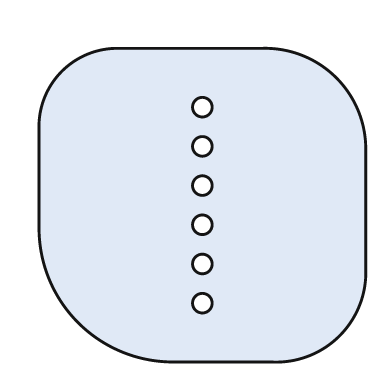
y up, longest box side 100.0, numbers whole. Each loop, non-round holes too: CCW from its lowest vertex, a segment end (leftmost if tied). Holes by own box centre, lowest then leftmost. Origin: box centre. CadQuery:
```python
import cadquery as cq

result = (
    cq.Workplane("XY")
    .moveTo(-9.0, -48.0)
    .lineTo(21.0, -48.0)
    .threePointArc((42.0, -40.0), (50.0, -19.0))
    .lineTo(50.0, 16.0)
    .threePointArc((41.0, 39.0), (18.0, 48.0))
    .lineTo(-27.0, 48.0)
    .threePointArc((-43.0, 41.0), (-50.0, 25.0))
    .lineTo(-50.0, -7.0)
    .threePointArc((-38.0, -36.0), (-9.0, -48.0))
    .close()
    .moveTo(0.0, -30.0)
    .circle(3.0)
    .moveTo(0.0, -18.0)
    .circle(3.0)
    .moveTo(0.0, -6.0)
    .circle(3.0)
    .moveTo(0.0, 6.0)
    .circle(3.0)
    .moveTo(0.0, 18.0)
    .circle(3.0)
    .moveTo(0.0, 30.0)
    .circle(3.0)
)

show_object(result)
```